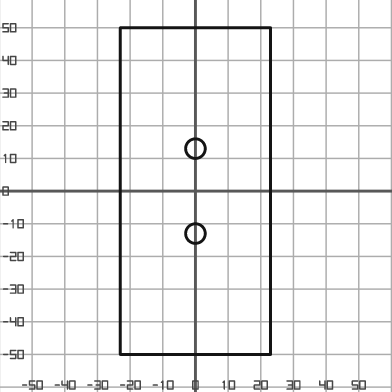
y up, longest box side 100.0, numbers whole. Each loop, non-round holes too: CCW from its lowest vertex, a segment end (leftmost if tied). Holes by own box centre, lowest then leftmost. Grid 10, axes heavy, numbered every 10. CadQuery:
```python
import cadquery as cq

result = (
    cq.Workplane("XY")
    .moveTo(-23.0, -50.0)
    .lineTo(23.0, -50.0)
    .lineTo(23.0, 50.0)
    .lineTo(-23.0, 50.0)
    .close()
    .moveTo(0.0, -13.0)
    .circle(3.0)
    .moveTo(0.0, 13.0)
    .circle(3.0)
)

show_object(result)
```